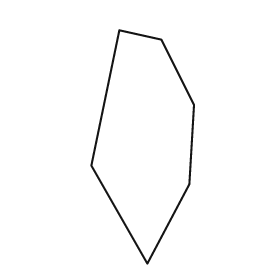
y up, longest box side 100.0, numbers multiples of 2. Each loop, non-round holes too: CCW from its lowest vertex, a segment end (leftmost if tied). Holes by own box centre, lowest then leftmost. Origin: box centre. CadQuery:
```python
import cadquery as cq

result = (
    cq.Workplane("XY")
    .moveTo(2.0, -50.0)
    .lineTo(20.0, -16.0)
    .lineTo(22.0, 18.0)
    .lineTo(8.0, 46.0)
    .lineTo(-10.0, 50.0)
    .lineTo(-22.0, -8.0)
    .close()
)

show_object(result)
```